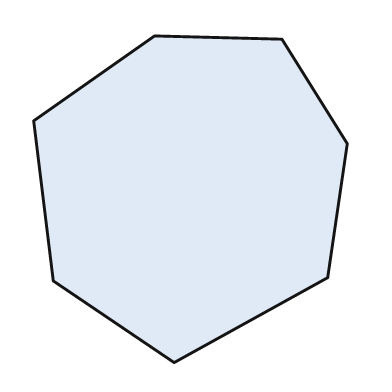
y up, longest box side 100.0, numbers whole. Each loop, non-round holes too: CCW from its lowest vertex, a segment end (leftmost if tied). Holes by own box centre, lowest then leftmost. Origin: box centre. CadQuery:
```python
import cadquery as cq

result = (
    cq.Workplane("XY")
    .moveTo(-5.0, -50.0)
    .lineTo(42.0, -24.0)
    .lineTo(48.0, 17.0)
    .lineTo(28.0, 49.0)
    .lineTo(-11.0, 50.0)
    .lineTo(-48.0, 24.0)
    .lineTo(-42.0, -25.0)
    .close()
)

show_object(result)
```